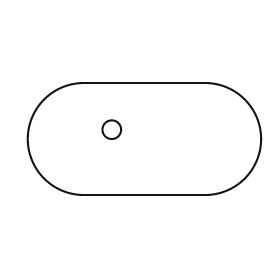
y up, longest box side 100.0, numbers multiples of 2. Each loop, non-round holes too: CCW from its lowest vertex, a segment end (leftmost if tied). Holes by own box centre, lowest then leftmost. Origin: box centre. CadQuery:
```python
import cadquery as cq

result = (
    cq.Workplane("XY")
    .moveTo(-26.0, -24.0)
    .lineTo(26.0, -24.0)
    .threePointArc((50.0, 0.0), (26.0, 24.0))
    .lineTo(-26.0, 24.0)
    .threePointArc((-50.0, 0.0), (-26.0, -24.0))
    .close()
    .moveTo(-14.0, 4.0)
    .circle(4.0)
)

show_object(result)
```